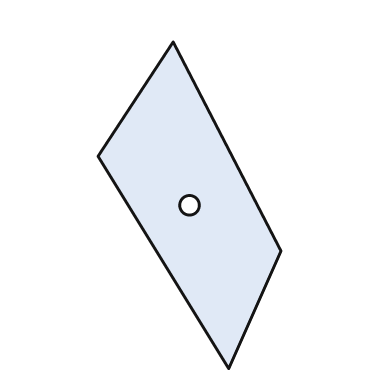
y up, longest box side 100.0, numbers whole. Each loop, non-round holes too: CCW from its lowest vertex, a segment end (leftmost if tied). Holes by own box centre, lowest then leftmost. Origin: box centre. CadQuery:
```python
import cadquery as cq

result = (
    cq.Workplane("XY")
    .moveTo(12.0, -50.0)
    .lineTo(28.0, -14.0)
    .lineTo(-5.0, 50.0)
    .lineTo(-28.0, 15.0)
    .close()
    .moveTo(0.0, 0.0)
    .circle(3.0)
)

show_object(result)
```